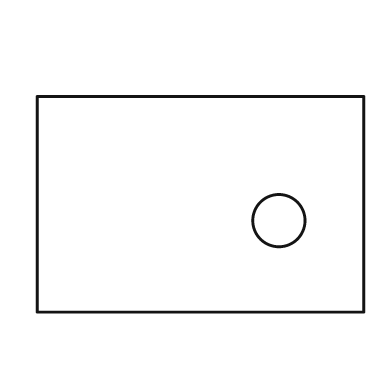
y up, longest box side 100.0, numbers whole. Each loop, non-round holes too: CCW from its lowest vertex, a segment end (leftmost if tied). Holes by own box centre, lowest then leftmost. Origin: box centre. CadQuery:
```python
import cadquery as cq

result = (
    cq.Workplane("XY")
    .moveTo(-50.0, -33.0)
    .lineTo(50.0, -33.0)
    .lineTo(50.0, 33.0)
    .lineTo(-50.0, 33.0)
    .close()
    .moveTo(24.0, -5.0)
    .circle(8.0)
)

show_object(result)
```